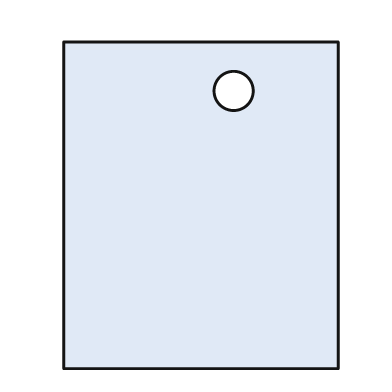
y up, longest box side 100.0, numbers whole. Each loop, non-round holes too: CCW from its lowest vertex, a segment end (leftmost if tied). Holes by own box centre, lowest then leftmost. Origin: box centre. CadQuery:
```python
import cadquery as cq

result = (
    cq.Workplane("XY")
    .moveTo(-42.0, -50.0)
    .lineTo(42.0, -50.0)
    .lineTo(42.0, 50.0)
    .lineTo(-42.0, 50.0)
    .close()
    .moveTo(10.0, 35.0)
    .circle(6.0)
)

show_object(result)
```